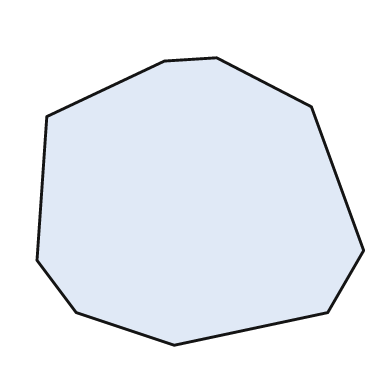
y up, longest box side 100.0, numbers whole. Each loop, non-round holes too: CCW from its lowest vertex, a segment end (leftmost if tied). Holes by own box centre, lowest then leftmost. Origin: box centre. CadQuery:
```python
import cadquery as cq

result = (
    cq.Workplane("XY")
    .moveTo(-8.0, -44.0)
    .lineTo(39.0, -34.0)
    .lineTo(50.0, -15.0)
    .lineTo(34.0, 29.0)
    .lineTo(5.0, 44.0)
    .lineTo(-11.0, 43.0)
    .lineTo(-47.0, 26.0)
    .lineTo(-50.0, -18.0)
    .lineTo(-38.0, -34.0)
    .close()
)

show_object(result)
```